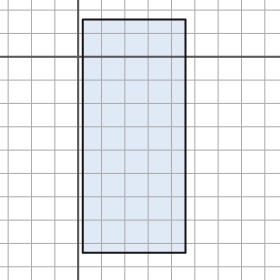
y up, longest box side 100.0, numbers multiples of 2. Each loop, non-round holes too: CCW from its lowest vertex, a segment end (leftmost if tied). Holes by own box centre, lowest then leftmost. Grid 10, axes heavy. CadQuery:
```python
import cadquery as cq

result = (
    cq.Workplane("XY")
    .moveTo(2.0, -84.0)
    .lineTo(46.0, -84.0)
    .lineTo(46.0, 16.0)
    .lineTo(2.0, 16.0)
    .close()
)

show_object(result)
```